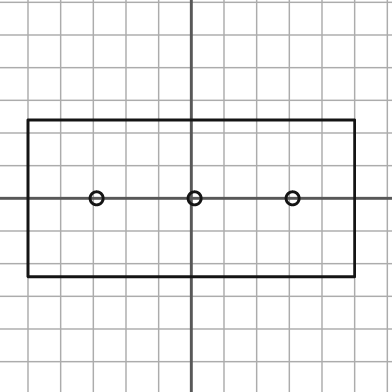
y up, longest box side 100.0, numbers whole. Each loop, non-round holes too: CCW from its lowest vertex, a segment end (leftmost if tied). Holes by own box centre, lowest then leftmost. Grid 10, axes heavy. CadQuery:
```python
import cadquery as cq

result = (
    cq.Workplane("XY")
    .moveTo(-50.0, -24.0)
    .lineTo(50.0, -24.0)
    .lineTo(50.0, 24.0)
    .lineTo(-50.0, 24.0)
    .close()
    .moveTo(-29.0, 0.0)
    .circle(2.0)
    .moveTo(1.0, 0.0)
    .circle(2.0)
    .moveTo(31.0, 0.0)
    .circle(2.0)
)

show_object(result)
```